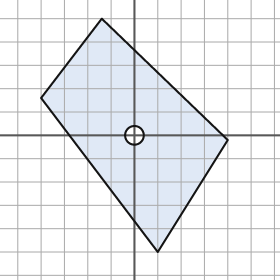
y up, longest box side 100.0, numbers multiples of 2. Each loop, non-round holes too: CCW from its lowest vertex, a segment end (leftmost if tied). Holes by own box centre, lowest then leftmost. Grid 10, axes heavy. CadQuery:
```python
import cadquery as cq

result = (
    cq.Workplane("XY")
    .moveTo(10.0, -50.0)
    .lineTo(40.0, -2.0)
    .lineTo(-14.0, 50.0)
    .lineTo(-40.0, 16.0)
    .close()
    .moveTo(0.0, 0.0)
    .circle(4.0)
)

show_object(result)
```